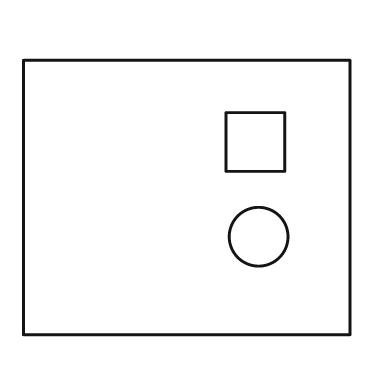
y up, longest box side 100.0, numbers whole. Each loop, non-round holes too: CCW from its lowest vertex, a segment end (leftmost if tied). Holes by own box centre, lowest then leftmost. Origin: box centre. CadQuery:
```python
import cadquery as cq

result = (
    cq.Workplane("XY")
    .moveTo(-50.0, -42.0)
    .lineTo(50.0, -42.0)
    .lineTo(50.0, 42.0)
    .lineTo(-50.0, 42.0)
    .close()
    .moveTo(22.0, -12.0)
    .circle(9.0)
    .moveTo(12.0, 8.0)
    .lineTo(30.0, 8.0)
    .lineTo(30.0, 26.0)
    .lineTo(12.0, 26.0)
    .close()
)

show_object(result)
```